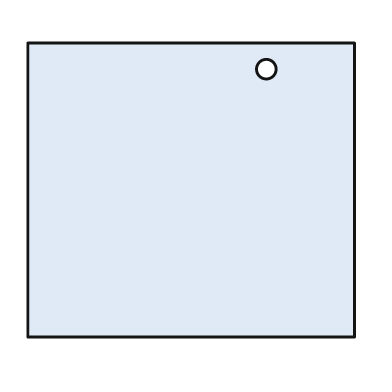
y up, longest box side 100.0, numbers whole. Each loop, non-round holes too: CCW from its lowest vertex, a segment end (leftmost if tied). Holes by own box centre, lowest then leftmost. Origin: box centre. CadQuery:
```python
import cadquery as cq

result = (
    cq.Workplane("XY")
    .moveTo(-50.0, -45.0)
    .lineTo(50.0, -45.0)
    .lineTo(50.0, 45.0)
    .lineTo(-50.0, 45.0)
    .close()
    .moveTo(23.0, 37.0)
    .circle(3.0)
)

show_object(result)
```